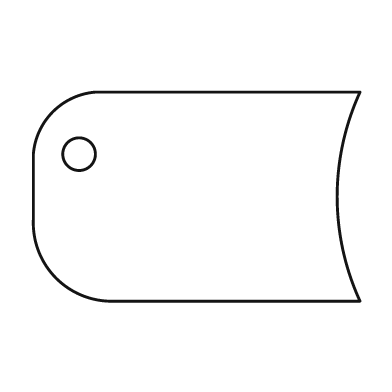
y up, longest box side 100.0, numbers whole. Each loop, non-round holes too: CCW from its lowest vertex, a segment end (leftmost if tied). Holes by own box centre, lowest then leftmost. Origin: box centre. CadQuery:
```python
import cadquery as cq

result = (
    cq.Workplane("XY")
    .moveTo(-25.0, -32.0)
    .lineTo(50.0, -32.0)
    .threePointArc((43.0, 0.0), (50.0, 32.0))
    .lineTo(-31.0, 32.0)
    .threePointArc((-44.0, 26.0), (-50.0, 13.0))
    .lineTo(-50.0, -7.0)
    .threePointArc((-43.0, -25.0), (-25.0, -32.0))
    .close()
    .moveTo(-36.0, 13.0)
    .circle(5.0)
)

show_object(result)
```